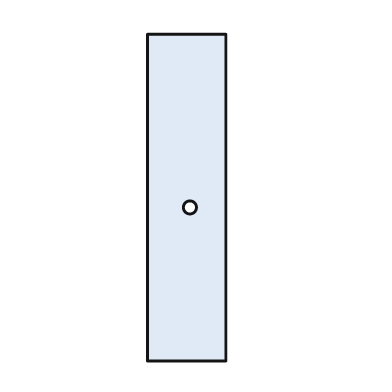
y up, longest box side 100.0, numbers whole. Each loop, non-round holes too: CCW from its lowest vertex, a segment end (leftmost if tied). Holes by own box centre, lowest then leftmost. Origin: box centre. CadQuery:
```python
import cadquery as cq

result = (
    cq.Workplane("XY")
    .moveTo(-12.0, -50.0)
    .lineTo(12.0, -50.0)
    .lineTo(12.0, 50.0)
    .lineTo(-12.0, 50.0)
    .close()
    .moveTo(1.0, -3.0)
    .circle(2.0)
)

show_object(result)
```